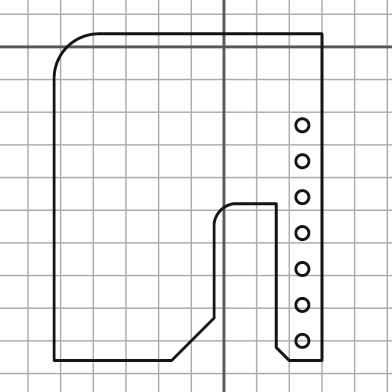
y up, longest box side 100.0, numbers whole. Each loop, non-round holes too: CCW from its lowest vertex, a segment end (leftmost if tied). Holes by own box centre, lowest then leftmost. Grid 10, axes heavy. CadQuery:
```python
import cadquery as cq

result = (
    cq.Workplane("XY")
    .moveTo(-52.0, -96.0)
    .lineTo(-16.0, -96.0)
    .lineTo(-3.0, -83.0)
    .lineTo(-3.0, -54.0)
    .threePointArc((-1.0, -50.0), (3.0, -48.0))
    .lineTo(16.0, -48.0)
    .lineTo(16.0, -92.0)
    .lineTo(20.0, -96.0)
    .lineTo(30.0, -96.0)
    .lineTo(30.0, 4.0)
    .lineTo(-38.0, 4.0)
    .threePointArc((-48.0, 0.0), (-52.0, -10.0))
    .close()
    .moveTo(24.0, -90.0)
    .circle(2.0)
    .moveTo(24.0, -79.0)
    .circle(2.0)
    .moveTo(24.0, -68.0)
    .circle(2.0)
    .moveTo(24.0, -57.0)
    .circle(2.0)
    .moveTo(24.0, -46.0)
    .circle(2.0)
    .moveTo(24.0, -35.0)
    .circle(2.0)
    .moveTo(24.0, -24.0)
    .circle(2.0)
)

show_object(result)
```